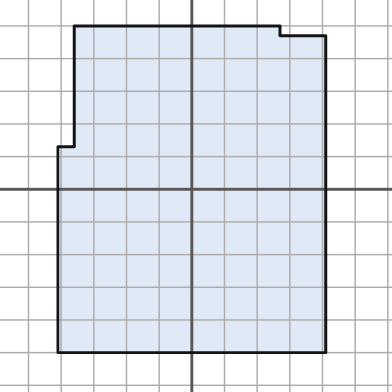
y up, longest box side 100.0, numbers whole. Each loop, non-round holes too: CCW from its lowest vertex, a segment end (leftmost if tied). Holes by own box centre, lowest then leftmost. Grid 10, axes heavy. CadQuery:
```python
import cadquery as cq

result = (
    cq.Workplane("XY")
    .moveTo(-41.0, -50.0)
    .lineTo(41.0, -50.0)
    .lineTo(41.0, 47.0)
    .lineTo(27.0, 47.0)
    .lineTo(27.0, 50.0)
    .lineTo(-36.0, 50.0)
    .lineTo(-36.0, 13.0)
    .lineTo(-41.0, 13.0)
    .close()
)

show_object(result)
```